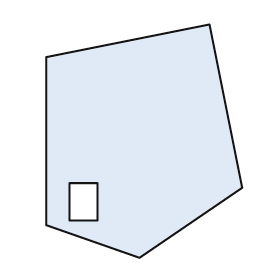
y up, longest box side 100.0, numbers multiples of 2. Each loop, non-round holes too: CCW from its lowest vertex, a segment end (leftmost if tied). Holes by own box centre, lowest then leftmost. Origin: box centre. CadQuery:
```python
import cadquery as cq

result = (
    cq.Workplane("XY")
    .moveTo(-2.0, -50.0)
    .lineTo(42.0, -20.0)
    .lineTo(28.0, 50.0)
    .lineTo(-42.0, 36.0)
    .lineTo(-42.0, -36.0)
    .close()
    .moveTo(-32.0, -34.0)
    .lineTo(-20.0, -34.0)
    .lineTo(-20.0, -18.0)
    .lineTo(-32.0, -18.0)
    .close()
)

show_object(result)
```